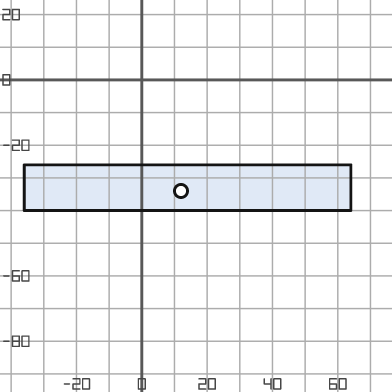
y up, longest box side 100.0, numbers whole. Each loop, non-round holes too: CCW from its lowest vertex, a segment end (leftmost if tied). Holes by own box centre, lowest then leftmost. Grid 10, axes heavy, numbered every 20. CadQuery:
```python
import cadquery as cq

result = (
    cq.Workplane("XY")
    .moveTo(-36.0, -40.0)
    .lineTo(64.0, -40.0)
    .lineTo(64.0, -26.0)
    .lineTo(-36.0, -26.0)
    .close()
    .moveTo(12.0, -34.0)
    .circle(2.0)
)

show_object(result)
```